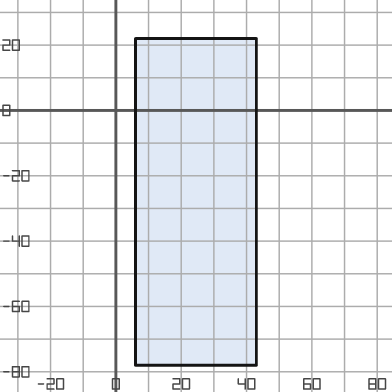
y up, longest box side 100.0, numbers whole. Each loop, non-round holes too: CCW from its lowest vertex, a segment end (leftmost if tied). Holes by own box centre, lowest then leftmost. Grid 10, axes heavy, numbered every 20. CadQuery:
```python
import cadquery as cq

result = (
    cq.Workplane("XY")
    .moveTo(6.0, -78.0)
    .lineTo(43.0, -78.0)
    .lineTo(43.0, 22.0)
    .lineTo(6.0, 22.0)
    .close()
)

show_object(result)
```